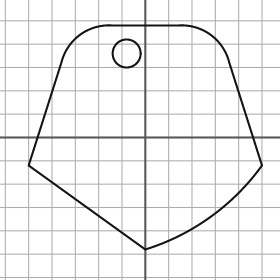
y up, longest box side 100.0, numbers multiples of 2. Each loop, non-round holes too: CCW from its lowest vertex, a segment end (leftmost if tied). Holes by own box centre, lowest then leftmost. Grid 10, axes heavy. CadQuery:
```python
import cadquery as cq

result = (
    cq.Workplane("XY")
    .moveTo(0.0, -48.0)
    .threePointArc((28.0, -34.0), (50.0, -12.0))
    .lineTo(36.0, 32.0)
    .threePointArc((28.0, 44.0), (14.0, 48.0))
    .lineTo(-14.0, 48.0)
    .threePointArc((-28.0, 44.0), (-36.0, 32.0))
    .lineTo(-50.0, -12.0)
    .close()
    .moveTo(-8.0, 36.0)
    .circle(6.0)
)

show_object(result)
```